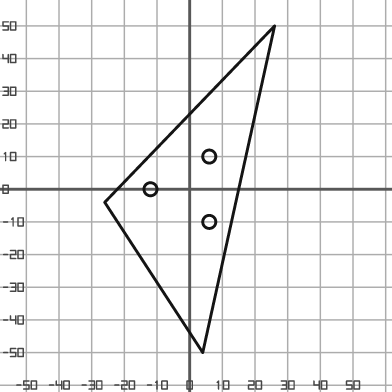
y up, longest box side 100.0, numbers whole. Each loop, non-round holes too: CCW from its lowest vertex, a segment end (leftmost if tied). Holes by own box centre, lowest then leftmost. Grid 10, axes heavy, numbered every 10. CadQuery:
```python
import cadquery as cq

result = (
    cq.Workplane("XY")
    .moveTo(4.0, -50.0)
    .lineTo(26.0, 50.0)
    .lineTo(-26.0, -4.0)
    .close()
    .moveTo(6.0, -10.0)
    .circle(2.0)
    .moveTo(-12.0, 0.0)
    .circle(2.0)
    .moveTo(6.0, 10.0)
    .circle(2.0)
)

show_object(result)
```